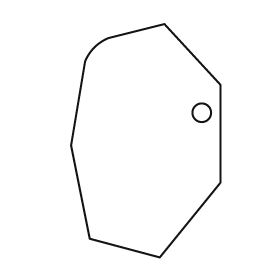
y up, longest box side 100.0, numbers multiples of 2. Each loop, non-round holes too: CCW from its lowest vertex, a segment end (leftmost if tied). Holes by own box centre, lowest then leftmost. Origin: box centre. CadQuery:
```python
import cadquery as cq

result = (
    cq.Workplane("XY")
    .moveTo(6.0, -50.0)
    .lineTo(32.0, -18.0)
    .lineTo(32.0, 24.0)
    .lineTo(8.0, 50.0)
    .lineTo(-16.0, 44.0)
    .threePointArc((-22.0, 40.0), (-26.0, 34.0))
    .lineTo(-32.0, -2.0)
    .lineTo(-24.0, -42.0)
    .close()
    .moveTo(24.0, 12.0)
    .circle(4.0)
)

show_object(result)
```